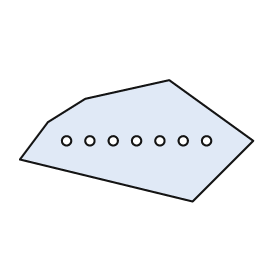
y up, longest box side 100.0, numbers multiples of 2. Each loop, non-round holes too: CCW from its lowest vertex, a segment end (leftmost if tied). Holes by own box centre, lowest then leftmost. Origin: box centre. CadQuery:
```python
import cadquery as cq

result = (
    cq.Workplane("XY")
    .moveTo(24.0, -26.0)
    .lineTo(50.0, 0.0)
    .lineTo(14.0, 26.0)
    .lineTo(-22.0, 18.0)
    .lineTo(-38.0, 8.0)
    .lineTo(-50.0, -8.0)
    .close()
    .moveTo(-30.0, 0.0)
    .circle(2.0)
    .moveTo(-20.0, 0.0)
    .circle(2.0)
    .moveTo(-10.0, 0.0)
    .circle(2.0)
    .moveTo(0.0, 0.0)
    .circle(2.0)
    .moveTo(10.0, 0.0)
    .circle(2.0)
    .moveTo(20.0, 0.0)
    .circle(2.0)
    .moveTo(30.0, 0.0)
    .circle(2.0)
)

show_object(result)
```